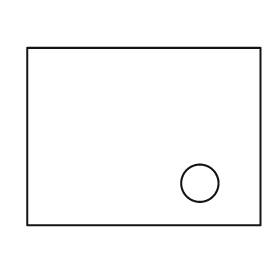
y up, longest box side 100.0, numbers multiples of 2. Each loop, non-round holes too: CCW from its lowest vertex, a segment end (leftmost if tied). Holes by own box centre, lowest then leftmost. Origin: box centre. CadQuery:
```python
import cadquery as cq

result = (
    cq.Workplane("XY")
    .moveTo(-50.0, -38.0)
    .lineTo(50.0, -38.0)
    .lineTo(50.0, 38.0)
    .lineTo(-50.0, 38.0)
    .close()
    .moveTo(24.0, -20.0)
    .circle(8.0)
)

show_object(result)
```